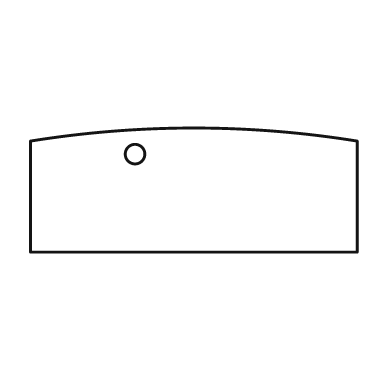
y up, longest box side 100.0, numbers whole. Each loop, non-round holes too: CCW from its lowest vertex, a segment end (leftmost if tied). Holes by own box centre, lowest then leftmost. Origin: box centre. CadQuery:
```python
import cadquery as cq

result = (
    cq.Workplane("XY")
    .moveTo(-50.0, -19.0)
    .lineTo(50.0, -19.0)
    .lineTo(50.0, 15.0)
    .threePointArc((0.0, 19.0), (-50.0, 15.0))
    .close()
    .moveTo(-18.0, 11.0)
    .circle(3.0)
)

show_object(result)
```